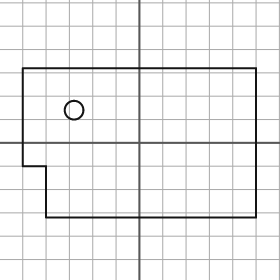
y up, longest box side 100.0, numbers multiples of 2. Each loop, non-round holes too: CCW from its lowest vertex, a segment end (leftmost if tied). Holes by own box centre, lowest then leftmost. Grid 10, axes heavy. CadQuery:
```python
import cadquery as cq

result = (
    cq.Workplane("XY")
    .moveTo(-40.0, -32.0)
    .lineTo(50.0, -32.0)
    .lineTo(50.0, 32.0)
    .lineTo(-50.0, 32.0)
    .lineTo(-50.0, -10.0)
    .lineTo(-40.0, -10.0)
    .close()
    .moveTo(-28.0, 14.0)
    .circle(4.0)
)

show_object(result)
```